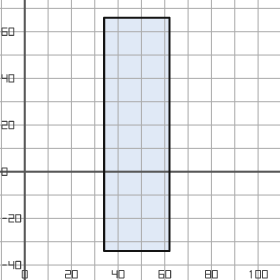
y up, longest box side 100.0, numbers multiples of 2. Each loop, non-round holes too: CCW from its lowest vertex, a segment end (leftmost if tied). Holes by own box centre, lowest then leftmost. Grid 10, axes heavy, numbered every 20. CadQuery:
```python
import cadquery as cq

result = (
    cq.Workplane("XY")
    .moveTo(34.0, -34.0)
    .lineTo(62.0, -34.0)
    .lineTo(62.0, 66.0)
    .lineTo(34.0, 66.0)
    .close()
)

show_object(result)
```